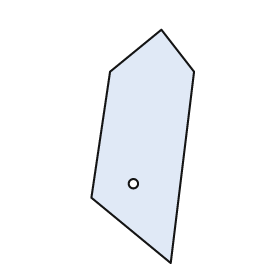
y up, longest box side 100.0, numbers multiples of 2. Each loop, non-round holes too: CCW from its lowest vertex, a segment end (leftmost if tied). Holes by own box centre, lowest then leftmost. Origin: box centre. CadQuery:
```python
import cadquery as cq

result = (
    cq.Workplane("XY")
    .moveTo(12.0, -50.0)
    .lineTo(22.0, 32.0)
    .lineTo(8.0, 50.0)
    .lineTo(-14.0, 32.0)
    .lineTo(-22.0, -22.0)
    .close()
    .moveTo(-4.0, -16.0)
    .circle(2.0)
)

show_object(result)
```